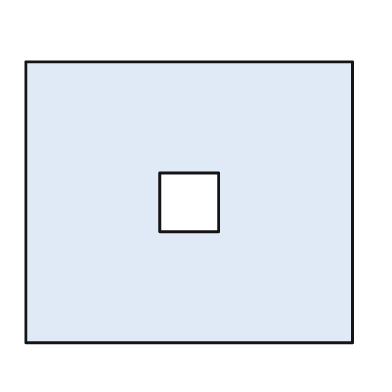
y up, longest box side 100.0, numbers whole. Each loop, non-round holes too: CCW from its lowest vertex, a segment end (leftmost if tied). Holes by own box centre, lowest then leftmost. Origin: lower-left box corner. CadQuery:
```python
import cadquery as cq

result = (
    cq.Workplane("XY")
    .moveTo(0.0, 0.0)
    .lineTo(100.0, 0.0)
    .lineTo(100.0, 86.0)
    .lineTo(0.0, 86.0)
    .close()
    .moveTo(41.0, 34.0)
    .lineTo(59.0, 34.0)
    .lineTo(59.0, 52.0)
    .lineTo(41.0, 52.0)
    .close()
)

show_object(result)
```